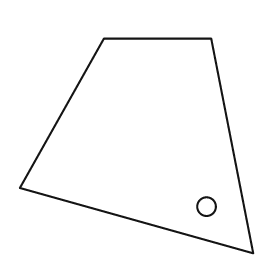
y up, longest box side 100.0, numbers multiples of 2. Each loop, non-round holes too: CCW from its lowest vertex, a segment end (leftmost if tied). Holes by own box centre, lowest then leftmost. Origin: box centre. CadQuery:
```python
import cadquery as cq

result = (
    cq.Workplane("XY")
    .moveTo(50.0, -46.0)
    .lineTo(32.0, 46.0)
    .lineTo(-14.0, 46.0)
    .lineTo(-50.0, -18.0)
    .close()
    .moveTo(30.0, -26.0)
    .circle(4.0)
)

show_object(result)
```